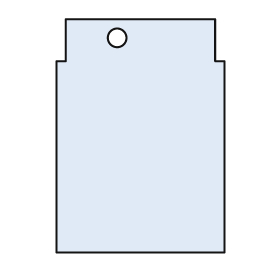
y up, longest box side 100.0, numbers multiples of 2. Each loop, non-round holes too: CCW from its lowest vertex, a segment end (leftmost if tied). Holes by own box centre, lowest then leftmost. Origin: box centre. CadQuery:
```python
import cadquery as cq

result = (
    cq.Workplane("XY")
    .moveTo(-36.0, -50.0)
    .lineTo(36.0, -50.0)
    .lineTo(36.0, 32.0)
    .lineTo(32.0, 32.0)
    .lineTo(32.0, 50.0)
    .lineTo(-32.0, 50.0)
    .lineTo(-32.0, 32.0)
    .lineTo(-36.0, 32.0)
    .close()
    .moveTo(-10.0, 42.0)
    .circle(4.0)
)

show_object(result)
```